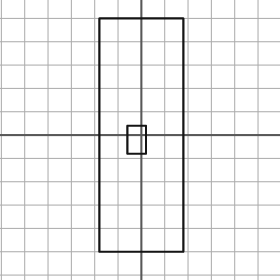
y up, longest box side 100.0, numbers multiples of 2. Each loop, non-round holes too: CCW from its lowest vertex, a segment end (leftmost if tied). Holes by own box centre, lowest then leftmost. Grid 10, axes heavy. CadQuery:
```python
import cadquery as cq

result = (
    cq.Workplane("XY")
    .moveTo(-18.0, -50.0)
    .lineTo(18.0, -50.0)
    .lineTo(18.0, 50.0)
    .lineTo(-18.0, 50.0)
    .close()
    .moveTo(-6.0, -8.0)
    .lineTo(2.0, -8.0)
    .lineTo(2.0, 4.0)
    .lineTo(-6.0, 4.0)
    .close()
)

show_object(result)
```